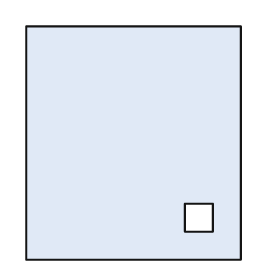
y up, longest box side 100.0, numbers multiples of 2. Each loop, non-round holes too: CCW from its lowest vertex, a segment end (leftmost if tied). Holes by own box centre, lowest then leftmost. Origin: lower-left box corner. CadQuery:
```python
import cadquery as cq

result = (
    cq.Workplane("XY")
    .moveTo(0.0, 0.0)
    .lineTo(92.0, 0.0)
    .lineTo(92.0, 100.0)
    .lineTo(0.0, 100.0)
    .close()
    .moveTo(68.0, 12.0)
    .lineTo(80.0, 12.0)
    .lineTo(80.0, 24.0)
    .lineTo(68.0, 24.0)
    .close()
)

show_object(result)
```